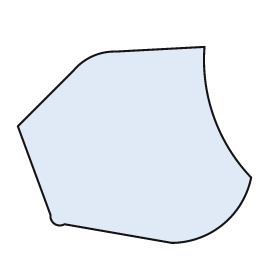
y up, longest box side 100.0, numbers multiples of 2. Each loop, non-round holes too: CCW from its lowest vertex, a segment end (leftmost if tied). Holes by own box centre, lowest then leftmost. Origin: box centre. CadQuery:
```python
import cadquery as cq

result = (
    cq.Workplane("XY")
    .moveTo(16.0, -42.0)
    .threePointArc((38.0, -34.0), (50.0, -14.0))
    .threePointArc((34.0, 12.0), (30.0, 42.0))
    .lineTo(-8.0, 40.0)
    .threePointArc((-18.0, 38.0), (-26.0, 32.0))
    .lineTo(-50.0, 8.0)
    .lineTo(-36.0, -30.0)
    .threePointArc((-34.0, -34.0), (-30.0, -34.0))
    .close()
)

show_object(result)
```